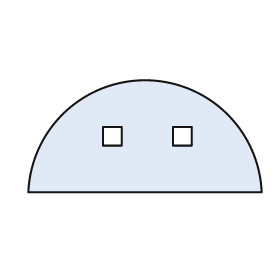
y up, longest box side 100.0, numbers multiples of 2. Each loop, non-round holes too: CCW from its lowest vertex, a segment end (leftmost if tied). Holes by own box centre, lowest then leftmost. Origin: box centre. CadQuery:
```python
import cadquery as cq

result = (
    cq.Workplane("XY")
    .moveTo(-50.0, -24.0)
    .lineTo(50.0, -24.0)
    .threePointArc((0.0, 24.0), (-50.0, -24.0))
    .close()
    .moveTo(-18.0, -4.0)
    .lineTo(-10.0, -4.0)
    .lineTo(-10.0, 4.0)
    .lineTo(-18.0, 4.0)
    .close()
    .moveTo(12.0, -4.0)
    .lineTo(20.0, -4.0)
    .lineTo(20.0, 4.0)
    .lineTo(12.0, 4.0)
    .close()
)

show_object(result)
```